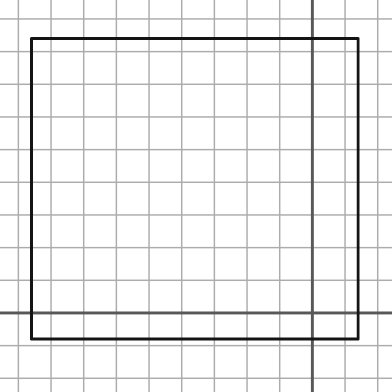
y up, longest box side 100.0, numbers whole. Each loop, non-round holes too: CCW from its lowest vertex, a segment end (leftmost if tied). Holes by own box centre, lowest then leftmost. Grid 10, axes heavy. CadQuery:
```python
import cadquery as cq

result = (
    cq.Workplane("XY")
    .moveTo(-86.0, -8.0)
    .lineTo(14.0, -8.0)
    .lineTo(14.0, 84.0)
    .lineTo(-86.0, 84.0)
    .close()
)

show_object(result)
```